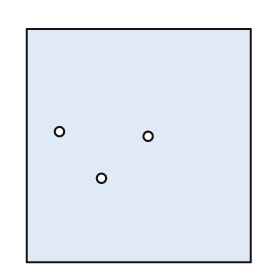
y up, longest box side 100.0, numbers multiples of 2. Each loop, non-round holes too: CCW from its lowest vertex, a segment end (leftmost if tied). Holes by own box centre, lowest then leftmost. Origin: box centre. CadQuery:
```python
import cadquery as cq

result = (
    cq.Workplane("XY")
    .moveTo(-48.0, -50.0)
    .lineTo(48.0, -50.0)
    .lineTo(48.0, 50.0)
    .lineTo(-48.0, 50.0)
    .close()
    .moveTo(-16.0, -14.0)
    .circle(2.0)
    .moveTo(4.0, 4.0)
    .circle(2.0)
    .moveTo(-34.0, 6.0)
    .circle(2.0)
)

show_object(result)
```